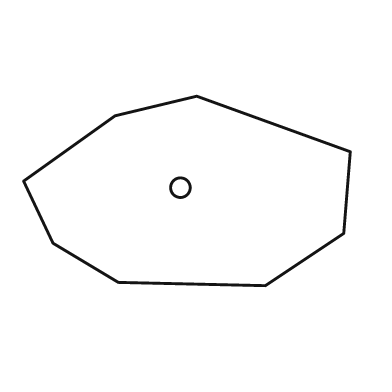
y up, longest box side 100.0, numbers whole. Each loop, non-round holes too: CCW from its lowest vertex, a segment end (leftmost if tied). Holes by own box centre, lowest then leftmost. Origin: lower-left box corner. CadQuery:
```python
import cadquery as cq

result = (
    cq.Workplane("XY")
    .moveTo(74.0, 0.0)
    .lineTo(98.0, 16.0)
    .lineTo(100.0, 41.0)
    .lineTo(53.0, 58.0)
    .lineTo(28.0, 52.0)
    .lineTo(0.0, 32.0)
    .lineTo(9.0, 13.0)
    .lineTo(29.0, 1.0)
    .close()
    .moveTo(48.0, 30.0)
    .circle(3.0)
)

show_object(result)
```